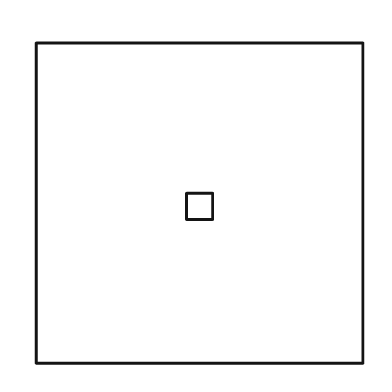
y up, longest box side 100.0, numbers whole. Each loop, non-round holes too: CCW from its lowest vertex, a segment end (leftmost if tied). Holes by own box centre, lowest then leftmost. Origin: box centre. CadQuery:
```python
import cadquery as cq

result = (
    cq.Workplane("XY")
    .moveTo(-50.0, -49.0)
    .lineTo(50.0, -49.0)
    .lineTo(50.0, 49.0)
    .lineTo(-50.0, 49.0)
    .close()
    .moveTo(-4.0, -5.0)
    .lineTo(4.0, -5.0)
    .lineTo(4.0, 3.0)
    .lineTo(-4.0, 3.0)
    .close()
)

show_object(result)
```